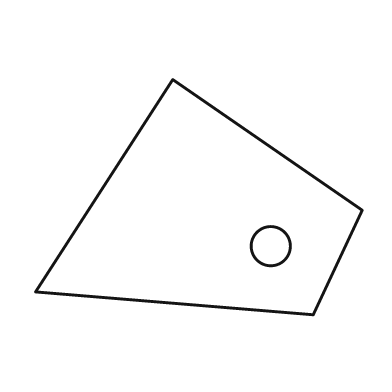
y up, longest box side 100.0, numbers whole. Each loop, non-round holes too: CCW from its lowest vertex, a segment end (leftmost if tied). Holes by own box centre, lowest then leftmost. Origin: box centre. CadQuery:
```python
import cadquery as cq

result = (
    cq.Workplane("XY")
    .moveTo(35.0, -36.0)
    .lineTo(50.0, -4.0)
    .lineTo(-8.0, 36.0)
    .lineTo(-50.0, -29.0)
    .close()
    .moveTo(22.0, -15.0)
    .circle(6.0)
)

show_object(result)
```